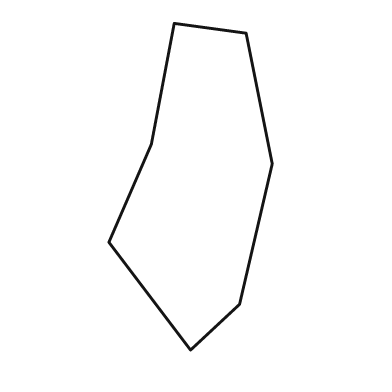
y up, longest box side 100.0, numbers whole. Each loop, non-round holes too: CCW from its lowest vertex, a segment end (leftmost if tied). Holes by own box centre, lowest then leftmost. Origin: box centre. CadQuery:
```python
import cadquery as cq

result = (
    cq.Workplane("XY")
    .moveTo(0.0, -50.0)
    .lineTo(15.0, -36.0)
    .lineTo(25.0, 7.0)
    .lineTo(17.0, 47.0)
    .lineTo(-5.0, 50.0)
    .lineTo(-12.0, 13.0)
    .lineTo(-25.0, -17.0)
    .close()
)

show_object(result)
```